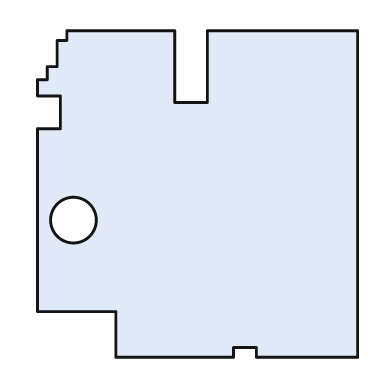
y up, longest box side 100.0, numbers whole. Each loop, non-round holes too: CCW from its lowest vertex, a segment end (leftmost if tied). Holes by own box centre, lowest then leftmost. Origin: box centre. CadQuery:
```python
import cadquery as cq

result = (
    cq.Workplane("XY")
    .moveTo(-25.0, -50.0)
    .lineTo(11.0, -50.0)
    .lineTo(11.0, -47.0)
    .lineTo(18.0, -47.0)
    .lineTo(18.0, -50.0)
    .lineTo(49.0, -50.0)
    .lineTo(49.0, 50.0)
    .lineTo(3.0, 50.0)
    .lineTo(3.0, 28.0)
    .lineTo(-7.0, 28.0)
    .lineTo(-7.0, 50.0)
    .lineTo(-40.0, 50.0)
    .lineTo(-40.0, 47.0)
    .lineTo(-43.0, 47.0)
    .lineTo(-43.0, 39.0)
    .lineTo(-46.0, 39.0)
    .lineTo(-46.0, 35.0)
    .lineTo(-49.0, 35.0)
    .lineTo(-49.0, 30.0)
    .lineTo(-42.0, 30.0)
    .lineTo(-42.0, 20.0)
    .lineTo(-49.0, 20.0)
    .lineTo(-49.0, -36.0)
    .lineTo(-25.0, -36.0)
    .close()
    .moveTo(-38.0, -8.0)
    .circle(7.0)
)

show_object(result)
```